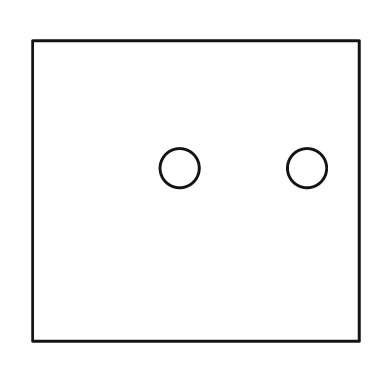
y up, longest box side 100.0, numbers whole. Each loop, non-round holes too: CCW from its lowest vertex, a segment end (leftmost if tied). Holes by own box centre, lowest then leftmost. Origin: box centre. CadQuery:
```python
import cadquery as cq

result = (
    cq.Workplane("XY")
    .moveTo(-50.0, -46.0)
    .lineTo(50.0, -46.0)
    .lineTo(50.0, 46.0)
    .lineTo(-50.0, 46.0)
    .close()
    .moveTo(-5.0, 7.0)
    .circle(6.0)
    .moveTo(34.0, 7.0)
    .circle(6.0)
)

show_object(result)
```